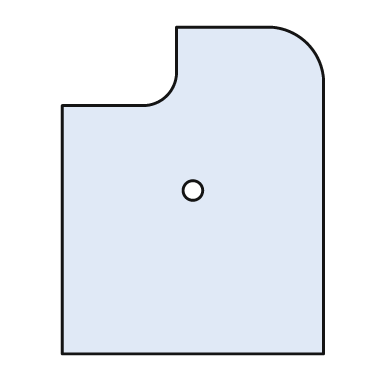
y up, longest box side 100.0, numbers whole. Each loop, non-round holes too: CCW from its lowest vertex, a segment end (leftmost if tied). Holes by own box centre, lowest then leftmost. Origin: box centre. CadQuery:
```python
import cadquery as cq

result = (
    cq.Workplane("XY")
    .moveTo(-40.0, -50.0)
    .lineTo(40.0, -50.0)
    .lineTo(40.0, 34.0)
    .threePointArc((35.0, 45.0), (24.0, 50.0))
    .lineTo(-5.0, 50.0)
    .lineTo(-5.0, 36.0)
    .threePointArc((-8.0, 29.0), (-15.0, 26.0))
    .lineTo(-40.0, 26.0)
    .close()
    .moveTo(0.0, 0.0)
    .circle(3.0)
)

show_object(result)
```